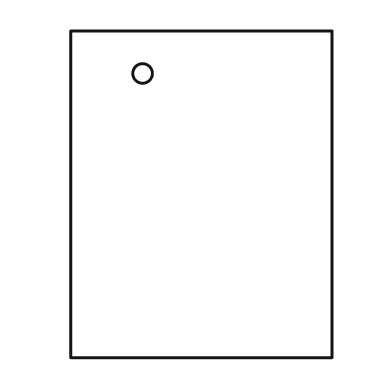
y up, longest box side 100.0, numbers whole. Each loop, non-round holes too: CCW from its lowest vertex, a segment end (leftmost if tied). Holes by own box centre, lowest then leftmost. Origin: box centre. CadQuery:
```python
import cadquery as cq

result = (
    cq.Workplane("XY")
    .moveTo(-40.0, -50.0)
    .lineTo(40.0, -50.0)
    .lineTo(40.0, 50.0)
    .lineTo(-40.0, 50.0)
    .close()
    .moveTo(-18.0, 37.0)
    .circle(3.0)
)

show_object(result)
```